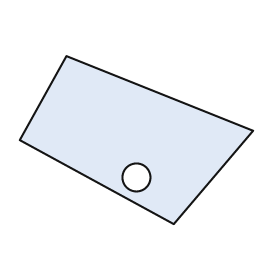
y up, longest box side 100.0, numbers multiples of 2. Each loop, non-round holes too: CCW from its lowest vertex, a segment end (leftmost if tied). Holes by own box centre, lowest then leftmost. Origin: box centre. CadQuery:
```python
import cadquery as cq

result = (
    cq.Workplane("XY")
    .moveTo(16.0, -36.0)
    .lineTo(50.0, 4.0)
    .lineTo(-30.0, 36.0)
    .lineTo(-50.0, 0.0)
    .close()
    .moveTo(0.0, -16.0)
    .circle(6.0)
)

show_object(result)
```